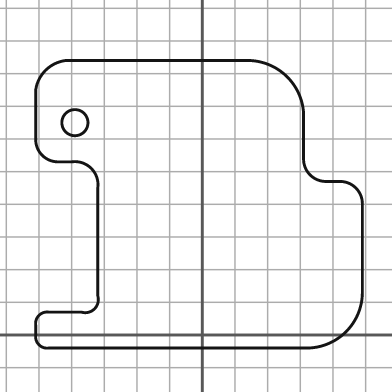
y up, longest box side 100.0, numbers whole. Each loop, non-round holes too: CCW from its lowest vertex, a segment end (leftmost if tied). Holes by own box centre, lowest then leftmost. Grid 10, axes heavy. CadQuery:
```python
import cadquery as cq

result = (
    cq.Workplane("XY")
    .moveTo(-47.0, -4.0)
    .lineTo(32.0, -4.0)
    .threePointArc((44.0, 1.0), (49.0, 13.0))
    .lineTo(49.0, 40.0)
    .threePointArc((47.0, 45.0), (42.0, 47.0))
    .lineTo(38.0, 47.0)
    .threePointArc((33.0, 49.0), (31.0, 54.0))
    .lineTo(31.0, 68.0)
    .threePointArc((26.0, 79.0), (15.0, 84.0))
    .lineTo(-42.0, 84.0)
    .threePointArc((-48.0, 81.0), (-51.0, 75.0))
    .lineTo(-51.0, 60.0)
    .threePointArc((-49.0, 55.0), (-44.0, 53.0))
    .lineTo(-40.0, 53.0)
    .threePointArc((-34.0, 51.0), (-32.0, 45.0))
    .lineTo(-32.0, 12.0)
    .threePointArc((-33.0, 8.0), (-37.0, 7.0))
    .lineTo(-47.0, 7.0)
    .threePointArc((-50.0, 6.0), (-51.0, 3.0))
    .lineTo(-51.0, 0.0)
    .threePointArc((-50.0, -3.0), (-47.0, -4.0))
    .close()
    .moveTo(-39.0, 65.0)
    .circle(4.0)
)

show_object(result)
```